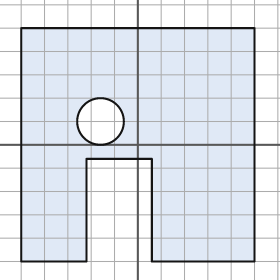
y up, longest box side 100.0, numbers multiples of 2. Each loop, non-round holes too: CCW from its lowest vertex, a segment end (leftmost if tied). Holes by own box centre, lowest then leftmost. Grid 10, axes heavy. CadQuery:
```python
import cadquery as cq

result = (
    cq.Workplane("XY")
    .moveTo(-50.0, -50.0)
    .lineTo(-22.0, -50.0)
    .lineTo(-22.0, -6.0)
    .lineTo(6.0, -6.0)
    .lineTo(6.0, -50.0)
    .lineTo(50.0, -50.0)
    .lineTo(50.0, 50.0)
    .lineTo(-50.0, 50.0)
    .close()
    .moveTo(-16.0, 10.0)
    .circle(10.0)
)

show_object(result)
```